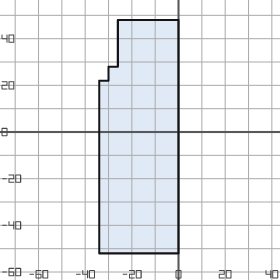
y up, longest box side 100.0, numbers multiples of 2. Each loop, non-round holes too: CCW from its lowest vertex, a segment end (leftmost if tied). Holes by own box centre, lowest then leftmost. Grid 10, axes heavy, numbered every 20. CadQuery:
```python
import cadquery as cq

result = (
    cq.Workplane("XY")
    .moveTo(-34.0, -52.0)
    .lineTo(0.0, -52.0)
    .lineTo(0.0, 48.0)
    .lineTo(-26.0, 48.0)
    .lineTo(-26.0, 28.0)
    .lineTo(-30.0, 28.0)
    .lineTo(-30.0, 22.0)
    .lineTo(-34.0, 22.0)
    .close()
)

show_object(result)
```